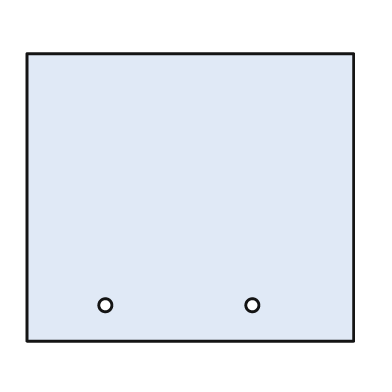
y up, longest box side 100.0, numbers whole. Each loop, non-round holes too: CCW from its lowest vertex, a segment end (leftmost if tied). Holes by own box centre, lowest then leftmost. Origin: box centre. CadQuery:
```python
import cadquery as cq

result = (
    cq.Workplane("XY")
    .moveTo(-50.0, -44.0)
    .lineTo(50.0, -44.0)
    .lineTo(50.0, 44.0)
    .lineTo(-50.0, 44.0)
    .close()
    .moveTo(-26.0, -33.0)
    .circle(2.0)
    .moveTo(19.0, -33.0)
    .circle(2.0)
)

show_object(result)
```